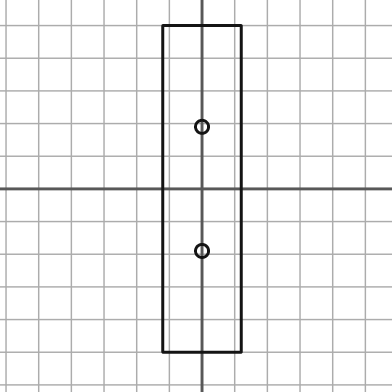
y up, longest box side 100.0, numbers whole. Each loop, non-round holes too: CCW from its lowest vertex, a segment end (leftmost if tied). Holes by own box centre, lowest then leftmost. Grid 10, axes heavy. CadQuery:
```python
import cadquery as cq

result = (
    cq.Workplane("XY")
    .moveTo(-12.0, -50.0)
    .lineTo(12.0, -50.0)
    .lineTo(12.0, 50.0)
    .lineTo(-12.0, 50.0)
    .close()
    .moveTo(0.0, -19.0)
    .circle(2.0)
    .moveTo(0.0, 19.0)
    .circle(2.0)
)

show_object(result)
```